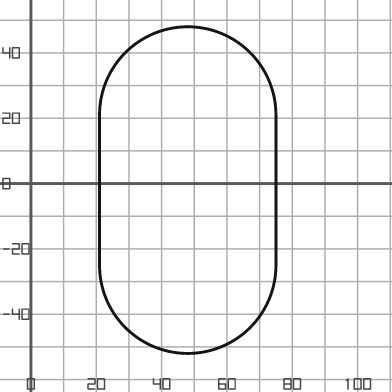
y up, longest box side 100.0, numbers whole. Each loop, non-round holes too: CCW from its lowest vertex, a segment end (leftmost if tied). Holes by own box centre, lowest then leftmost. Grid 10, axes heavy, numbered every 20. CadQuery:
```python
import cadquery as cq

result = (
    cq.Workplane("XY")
    .moveTo(21.0, -25.0)
    .threePointArc((48.0, -52.0), (75.0, -25.0))
    .lineTo(75.0, 21.0)
    .threePointArc((48.0, 48.0), (21.0, 21.0))
    .close()
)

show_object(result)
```